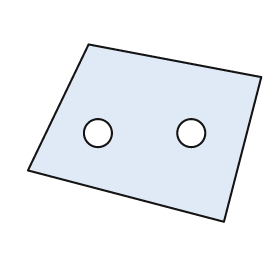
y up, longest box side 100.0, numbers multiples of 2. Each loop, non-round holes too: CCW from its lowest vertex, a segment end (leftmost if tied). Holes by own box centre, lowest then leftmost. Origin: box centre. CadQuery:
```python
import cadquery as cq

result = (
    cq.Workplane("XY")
    .moveTo(34.0, -38.0)
    .lineTo(50.0, 24.0)
    .lineTo(-24.0, 38.0)
    .lineTo(-50.0, -16.0)
    .close()
    .moveTo(-20.0, 0.0)
    .circle(6.0)
    .moveTo(20.0, 0.0)
    .circle(6.0)
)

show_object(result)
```